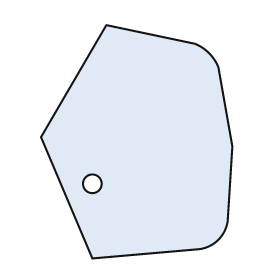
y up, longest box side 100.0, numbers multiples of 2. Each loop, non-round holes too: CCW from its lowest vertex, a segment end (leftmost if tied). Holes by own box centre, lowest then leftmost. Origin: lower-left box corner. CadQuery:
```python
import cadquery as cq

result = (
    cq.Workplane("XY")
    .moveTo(22.0, 0.0)
    .lineTo(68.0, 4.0)
    .threePointArc((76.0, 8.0), (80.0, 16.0))
    .lineTo(82.0, 48.0)
    .lineTo(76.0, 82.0)
    .threePointArc((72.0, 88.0), (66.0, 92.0))
    .lineTo(28.0, 100.0)
    .lineTo(0.0, 52.0)
    .close()
    .moveTo(22.0, 32.0)
    .circle(4.0)
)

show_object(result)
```